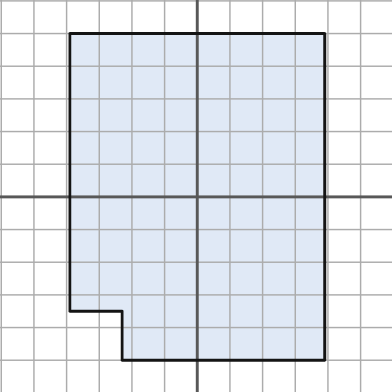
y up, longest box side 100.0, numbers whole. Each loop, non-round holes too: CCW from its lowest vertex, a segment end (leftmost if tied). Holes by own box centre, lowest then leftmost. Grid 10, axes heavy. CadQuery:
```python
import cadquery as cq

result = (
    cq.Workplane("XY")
    .moveTo(-23.0, -50.0)
    .lineTo(39.0, -50.0)
    .lineTo(39.0, 50.0)
    .lineTo(-39.0, 50.0)
    .lineTo(-39.0, -35.0)
    .lineTo(-23.0, -35.0)
    .close()
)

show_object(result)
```